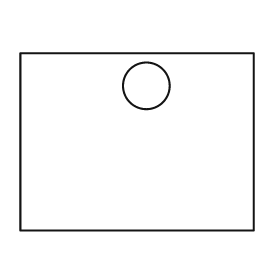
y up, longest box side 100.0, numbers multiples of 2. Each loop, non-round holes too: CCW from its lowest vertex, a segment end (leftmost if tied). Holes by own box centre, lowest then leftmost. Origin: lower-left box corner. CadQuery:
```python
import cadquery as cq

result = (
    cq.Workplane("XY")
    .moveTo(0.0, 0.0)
    .lineTo(100.0, 0.0)
    .lineTo(100.0, 76.0)
    .lineTo(0.0, 76.0)
    .close()
    .moveTo(54.0, 62.0)
    .circle(10.0)
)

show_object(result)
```